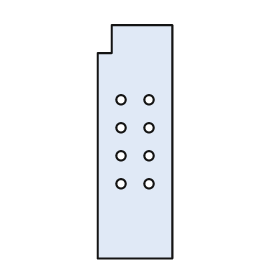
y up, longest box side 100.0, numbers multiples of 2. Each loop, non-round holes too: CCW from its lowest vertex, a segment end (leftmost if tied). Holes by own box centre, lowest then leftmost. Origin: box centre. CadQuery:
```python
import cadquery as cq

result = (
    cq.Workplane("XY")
    .moveTo(-16.0, -50.0)
    .lineTo(16.0, -50.0)
    .lineTo(16.0, 50.0)
    .lineTo(-10.0, 50.0)
    .lineTo(-10.0, 38.0)
    .lineTo(-16.0, 38.0)
    .close()
    .moveTo(-6.0, -18.0)
    .circle(2.0)
    .moveTo(6.0, -18.0)
    .circle(2.0)
    .moveTo(-6.0, -6.0)
    .circle(2.0)
    .moveTo(6.0, -6.0)
    .circle(2.0)
    .moveTo(-6.0, 6.0)
    .circle(2.0)
    .moveTo(6.0, 6.0)
    .circle(2.0)
    .moveTo(-6.0, 18.0)
    .circle(2.0)
    .moveTo(6.0, 18.0)
    .circle(2.0)
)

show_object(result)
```